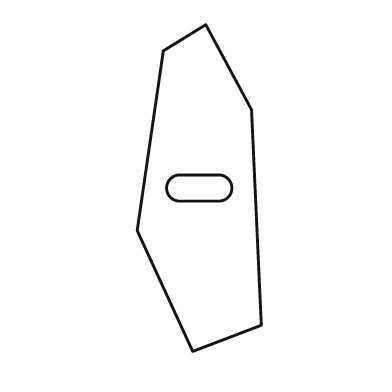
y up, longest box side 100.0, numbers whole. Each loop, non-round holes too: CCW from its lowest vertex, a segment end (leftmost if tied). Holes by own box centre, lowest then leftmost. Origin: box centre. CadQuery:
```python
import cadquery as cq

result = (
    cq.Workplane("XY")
    .moveTo(-2.0, -50.0)
    .lineTo(19.0, -42.0)
    .lineTo(16.0, 24.0)
    .lineTo(2.0, 50.0)
    .lineTo(-11.0, 42.0)
    .lineTo(-19.0, -13.0)
    .close()
    .moveTo(-6.0, -4.0)
    .lineTo(6.0, -4.0)
    .threePointArc((10.0, 0.0), (6.0, 4.0))
    .lineTo(-6.0, 4.0)
    .threePointArc((-10.0, 0.0), (-6.0, -4.0))
    .close()
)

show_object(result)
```